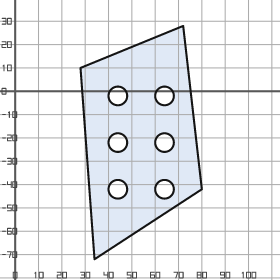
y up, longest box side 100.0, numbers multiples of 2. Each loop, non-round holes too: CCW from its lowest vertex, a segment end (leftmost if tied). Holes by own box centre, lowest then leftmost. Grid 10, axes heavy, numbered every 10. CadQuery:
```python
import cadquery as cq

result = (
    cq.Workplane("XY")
    .moveTo(34.0, -72.0)
    .lineTo(80.0, -42.0)
    .lineTo(72.0, 28.0)
    .lineTo(28.0, 10.0)
    .close()
    .moveTo(44.0, -42.0)
    .circle(4.0)
    .moveTo(64.0, -42.0)
    .circle(4.0)
    .moveTo(44.0, -22.0)
    .circle(4.0)
    .moveTo(64.0, -22.0)
    .circle(4.0)
    .moveTo(44.0, -2.0)
    .circle(4.0)
    .moveTo(64.0, -2.0)
    .circle(4.0)
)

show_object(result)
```